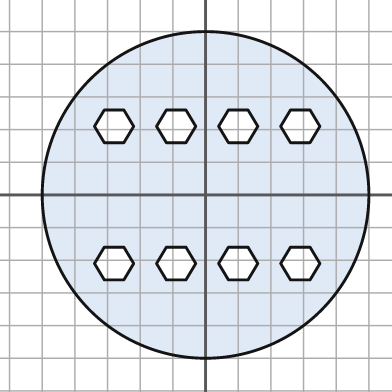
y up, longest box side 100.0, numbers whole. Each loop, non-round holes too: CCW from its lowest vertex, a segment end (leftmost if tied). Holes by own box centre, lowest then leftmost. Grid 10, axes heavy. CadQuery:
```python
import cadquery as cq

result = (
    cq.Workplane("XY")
    .moveTo(0.0, 0.0)
    .circle(50.0)
    .moveTo(-31.0, -26.0)
    .lineTo(-25.0, -26.0)
    .lineTo(-22.0, -21.0)
    .lineTo(-25.0, -16.0)
    .lineTo(-31.0, -16.0)
    .lineTo(-34.0, -21.0)
    .close()
    .moveTo(-12.0, -26.0)
    .lineTo(-6.0, -26.0)
    .lineTo(-3.0, -21.0)
    .lineTo(-6.0, -16.0)
    .lineTo(-12.0, -16.0)
    .lineTo(-15.0, -21.0)
    .close()
    .moveTo(7.0, -26.0)
    .lineTo(13.0, -26.0)
    .lineTo(16.0, -21.0)
    .lineTo(13.0, -16.0)
    .lineTo(7.0, -16.0)
    .lineTo(4.0, -21.0)
    .close()
    .moveTo(26.0, -26.0)
    .lineTo(32.0, -26.0)
    .lineTo(35.0, -21.0)
    .lineTo(32.0, -16.0)
    .lineTo(26.0, -16.0)
    .lineTo(23.0, -21.0)
    .close()
    .moveTo(-31.0, 16.0)
    .lineTo(-25.0, 16.0)
    .lineTo(-22.0, 21.0)
    .lineTo(-25.0, 26.0)
    .lineTo(-31.0, 26.0)
    .lineTo(-34.0, 21.0)
    .close()
    .moveTo(-12.0, 16.0)
    .lineTo(-6.0, 16.0)
    .lineTo(-3.0, 21.0)
    .lineTo(-6.0, 26.0)
    .lineTo(-12.0, 26.0)
    .lineTo(-15.0, 21.0)
    .close()
    .moveTo(7.0, 16.0)
    .lineTo(13.0, 16.0)
    .lineTo(16.0, 21.0)
    .lineTo(13.0, 26.0)
    .lineTo(7.0, 26.0)
    .lineTo(4.0, 21.0)
    .close()
    .moveTo(26.0, 16.0)
    .lineTo(32.0, 16.0)
    .lineTo(35.0, 21.0)
    .lineTo(32.0, 26.0)
    .lineTo(26.0, 26.0)
    .lineTo(23.0, 21.0)
    .close()
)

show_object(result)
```